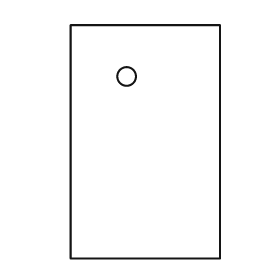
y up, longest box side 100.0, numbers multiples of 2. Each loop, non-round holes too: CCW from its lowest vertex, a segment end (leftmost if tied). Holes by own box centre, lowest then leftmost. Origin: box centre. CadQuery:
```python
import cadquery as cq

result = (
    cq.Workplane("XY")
    .moveTo(-32.0, -50.0)
    .lineTo(32.0, -50.0)
    .lineTo(32.0, 50.0)
    .lineTo(-32.0, 50.0)
    .close()
    .moveTo(-8.0, 28.0)
    .circle(4.0)
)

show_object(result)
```